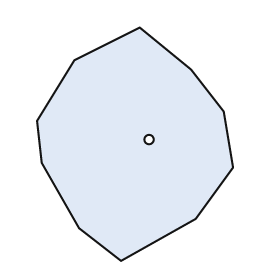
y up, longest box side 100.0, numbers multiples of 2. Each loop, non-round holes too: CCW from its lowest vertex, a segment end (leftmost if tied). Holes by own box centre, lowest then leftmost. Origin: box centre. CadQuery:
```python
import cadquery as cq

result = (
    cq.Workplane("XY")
    .moveTo(-6.0, -50.0)
    .lineTo(26.0, -32.0)
    .lineTo(42.0, -10.0)
    .lineTo(38.0, 14.0)
    .lineTo(24.0, 32.0)
    .lineTo(2.0, 50.0)
    .lineTo(-26.0, 36.0)
    .lineTo(-42.0, 10.0)
    .lineTo(-40.0, -8.0)
    .lineTo(-24.0, -36.0)
    .close()
    .moveTo(6.0, 2.0)
    .circle(2.0)
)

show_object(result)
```